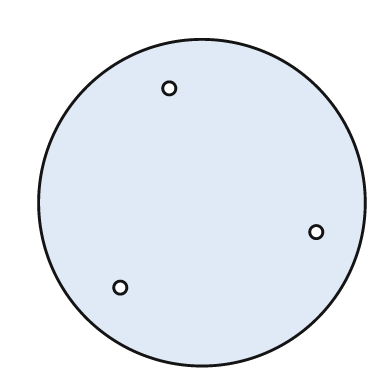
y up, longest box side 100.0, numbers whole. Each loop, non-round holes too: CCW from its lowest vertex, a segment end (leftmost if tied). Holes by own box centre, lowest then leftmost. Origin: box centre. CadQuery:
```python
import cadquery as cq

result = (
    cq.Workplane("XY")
    .moveTo(0.0, 0.0)
    .circle(50.0)
    .moveTo(-25.0, -26.0)
    .circle(2.0)
    .moveTo(35.0, -9.0)
    .circle(2.0)
    .moveTo(-10.0, 35.0)
    .circle(2.0)
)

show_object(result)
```